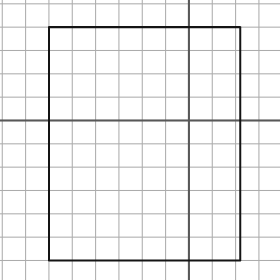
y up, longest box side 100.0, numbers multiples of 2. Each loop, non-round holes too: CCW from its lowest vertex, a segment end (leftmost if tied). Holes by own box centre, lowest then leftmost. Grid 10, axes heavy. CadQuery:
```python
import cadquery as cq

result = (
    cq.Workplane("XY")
    .moveTo(-60.0, -60.0)
    .lineTo(22.0, -60.0)
    .lineTo(22.0, 40.0)
    .lineTo(-60.0, 40.0)
    .close()
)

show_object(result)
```